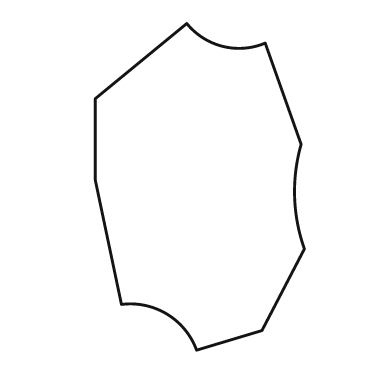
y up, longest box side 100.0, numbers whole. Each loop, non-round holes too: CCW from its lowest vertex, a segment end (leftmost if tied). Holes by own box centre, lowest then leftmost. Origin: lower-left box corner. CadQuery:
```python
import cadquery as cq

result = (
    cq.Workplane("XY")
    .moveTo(31.0, 0.0)
    .lineTo(51.0, 6.0)
    .lineTo(64.0, 31.0)
    .threePointArc((61.0, 47.0), (63.0, 63.0))
    .lineTo(52.0, 94.0)
    .threePointArc((39.0, 93.0), (28.0, 100.0))
    .lineTo(0.0, 77.0)
    .lineTo(0.0, 52.0)
    .lineTo(8.0, 14.0)
    .threePointArc((22.0, 11.0), (31.0, 0.0))
    .close()
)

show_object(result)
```